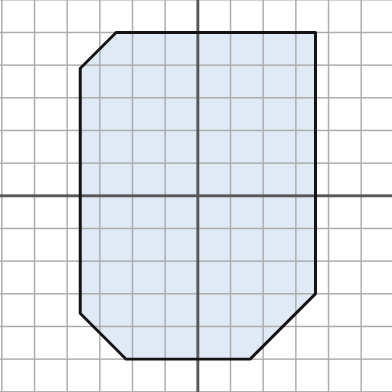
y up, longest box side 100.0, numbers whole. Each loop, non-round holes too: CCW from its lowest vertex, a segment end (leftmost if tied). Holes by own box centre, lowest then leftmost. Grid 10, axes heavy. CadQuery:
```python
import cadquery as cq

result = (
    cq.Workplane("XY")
    .moveTo(-22.0, -50.0)
    .lineTo(16.0, -50.0)
    .lineTo(36.0, -30.0)
    .lineTo(36.0, 50.0)
    .lineTo(-25.0, 50.0)
    .lineTo(-36.0, 39.0)
    .lineTo(-36.0, -36.0)
    .close()
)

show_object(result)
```